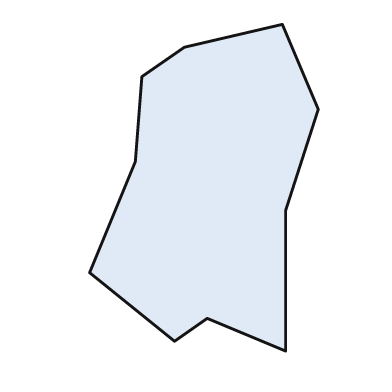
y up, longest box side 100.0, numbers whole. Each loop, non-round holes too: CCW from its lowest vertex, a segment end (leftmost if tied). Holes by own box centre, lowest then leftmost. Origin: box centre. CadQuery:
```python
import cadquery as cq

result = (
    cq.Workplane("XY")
    .moveTo(25.0, -50.0)
    .lineTo(25.0, -7.0)
    .lineTo(35.0, 24.0)
    .lineTo(24.0, 50.0)
    .lineTo(-6.0, 43.0)
    .lineTo(-19.0, 34.0)
    .lineTo(-21.0, 8.0)
    .lineTo(-35.0, -26.0)
    .lineTo(-9.0, -47.0)
    .lineTo(1.0, -40.0)
    .close()
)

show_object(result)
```